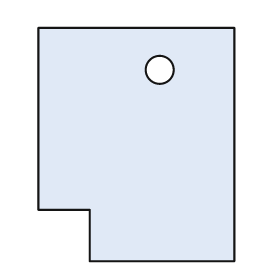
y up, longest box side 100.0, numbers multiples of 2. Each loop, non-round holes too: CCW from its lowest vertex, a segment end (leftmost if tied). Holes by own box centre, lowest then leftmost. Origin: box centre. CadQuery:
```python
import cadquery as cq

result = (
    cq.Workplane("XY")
    .moveTo(-20.0, -50.0)
    .lineTo(42.0, -50.0)
    .lineTo(42.0, 50.0)
    .lineTo(-42.0, 50.0)
    .lineTo(-42.0, -28.0)
    .lineTo(-20.0, -28.0)
    .close()
    .moveTo(10.0, 32.0)
    .circle(6.0)
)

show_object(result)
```